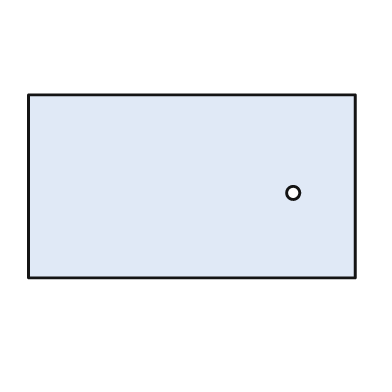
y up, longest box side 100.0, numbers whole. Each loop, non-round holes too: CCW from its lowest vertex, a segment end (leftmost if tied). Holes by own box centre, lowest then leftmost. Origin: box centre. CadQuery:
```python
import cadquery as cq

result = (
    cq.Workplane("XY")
    .moveTo(-50.0, -28.0)
    .lineTo(50.0, -28.0)
    .lineTo(50.0, 28.0)
    .lineTo(-50.0, 28.0)
    .close()
    .moveTo(31.0, -2.0)
    .circle(2.0)
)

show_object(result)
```